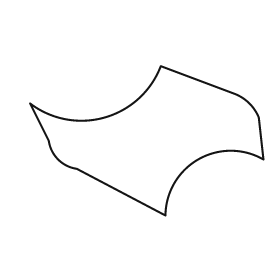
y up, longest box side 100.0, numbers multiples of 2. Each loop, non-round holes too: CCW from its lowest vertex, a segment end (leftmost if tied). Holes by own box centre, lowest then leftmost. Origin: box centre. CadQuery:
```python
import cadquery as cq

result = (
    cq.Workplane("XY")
    .moveTo(8.0, -32.0)
    .threePointArc((22.0, -8.0), (50.0, -8.0))
    .lineTo(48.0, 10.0)
    .threePointArc((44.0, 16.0), (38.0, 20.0))
    .lineTo(6.0, 32.0)
    .threePointArc((-18.0, 10.0), (-50.0, 16.0))
    .lineTo(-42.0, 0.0)
    .threePointArc((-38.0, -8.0), (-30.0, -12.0))
    .close()
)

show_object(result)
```